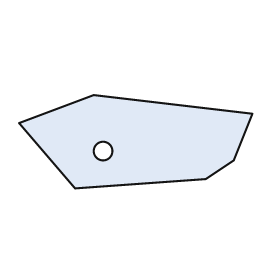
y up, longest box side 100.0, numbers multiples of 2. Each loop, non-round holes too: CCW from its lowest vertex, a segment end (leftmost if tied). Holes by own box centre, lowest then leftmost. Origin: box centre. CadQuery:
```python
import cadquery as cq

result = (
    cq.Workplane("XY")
    .moveTo(-26.0, -20.0)
    .lineTo(30.0, -16.0)
    .lineTo(42.0, -8.0)
    .lineTo(50.0, 12.0)
    .lineTo(-18.0, 20.0)
    .lineTo(-50.0, 8.0)
    .close()
    .moveTo(-14.0, -4.0)
    .circle(4.0)
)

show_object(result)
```